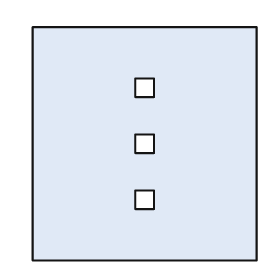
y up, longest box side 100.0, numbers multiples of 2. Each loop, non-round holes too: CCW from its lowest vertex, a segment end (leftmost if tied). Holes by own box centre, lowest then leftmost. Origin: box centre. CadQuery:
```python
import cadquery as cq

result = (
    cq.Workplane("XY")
    .moveTo(-48.0, -50.0)
    .lineTo(48.0, -50.0)
    .lineTo(48.0, 50.0)
    .lineTo(-48.0, 50.0)
    .close()
    .moveTo(-4.0, -28.0)
    .lineTo(4.0, -28.0)
    .lineTo(4.0, -20.0)
    .lineTo(-4.0, -20.0)
    .close()
    .moveTo(-4.0, -4.0)
    .lineTo(4.0, -4.0)
    .lineTo(4.0, 4.0)
    .lineTo(-4.0, 4.0)
    .close()
    .moveTo(-4.0, 20.0)
    .lineTo(4.0, 20.0)
    .lineTo(4.0, 28.0)
    .lineTo(-4.0, 28.0)
    .close()
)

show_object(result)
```